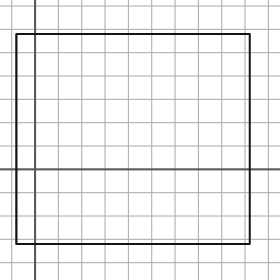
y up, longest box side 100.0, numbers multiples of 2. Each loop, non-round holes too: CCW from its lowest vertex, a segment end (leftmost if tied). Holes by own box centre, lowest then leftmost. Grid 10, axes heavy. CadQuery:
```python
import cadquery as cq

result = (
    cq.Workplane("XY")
    .moveTo(-8.0, -32.0)
    .lineTo(92.0, -32.0)
    .lineTo(92.0, 58.0)
    .lineTo(-8.0, 58.0)
    .close()
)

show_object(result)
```